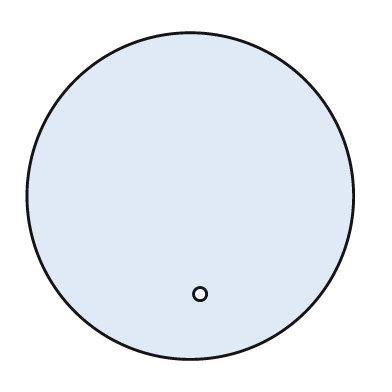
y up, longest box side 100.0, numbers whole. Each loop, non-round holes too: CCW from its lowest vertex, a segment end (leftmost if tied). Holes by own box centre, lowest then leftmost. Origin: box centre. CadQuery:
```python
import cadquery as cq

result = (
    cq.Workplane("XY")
    .moveTo(0.0, 0.0)
    .circle(50.0)
    .moveTo(3.0, -30.0)
    .circle(2.0)
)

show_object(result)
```